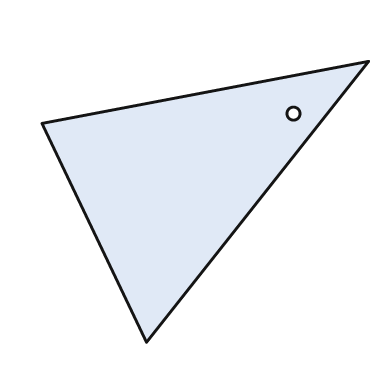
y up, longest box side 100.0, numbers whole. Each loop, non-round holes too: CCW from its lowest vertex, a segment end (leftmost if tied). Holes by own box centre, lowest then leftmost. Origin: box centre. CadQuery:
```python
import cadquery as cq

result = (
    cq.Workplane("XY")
    .moveTo(-18.0, -43.0)
    .lineTo(50.0, 43.0)
    .lineTo(-50.0, 24.0)
    .close()
    .moveTo(27.0, 27.0)
    .circle(2.0)
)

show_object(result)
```